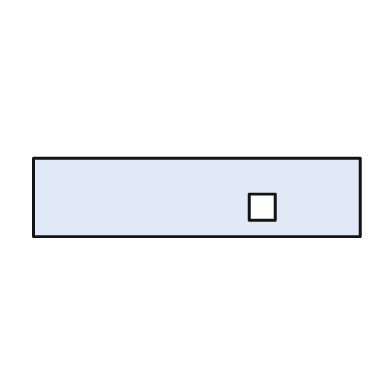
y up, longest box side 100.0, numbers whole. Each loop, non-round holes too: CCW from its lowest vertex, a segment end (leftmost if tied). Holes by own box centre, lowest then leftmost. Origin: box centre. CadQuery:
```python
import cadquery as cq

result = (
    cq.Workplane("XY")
    .moveTo(-50.0, -12.0)
    .lineTo(50.0, -12.0)
    .lineTo(50.0, 12.0)
    .lineTo(-50.0, 12.0)
    .close()
    .moveTo(16.0, -7.0)
    .lineTo(24.0, -7.0)
    .lineTo(24.0, 1.0)
    .lineTo(16.0, 1.0)
    .close()
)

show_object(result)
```